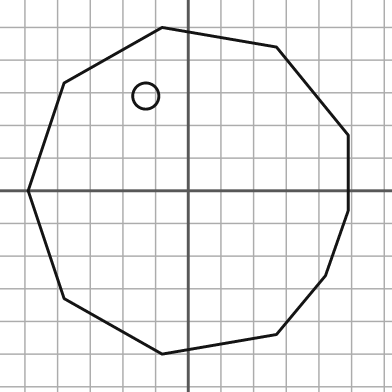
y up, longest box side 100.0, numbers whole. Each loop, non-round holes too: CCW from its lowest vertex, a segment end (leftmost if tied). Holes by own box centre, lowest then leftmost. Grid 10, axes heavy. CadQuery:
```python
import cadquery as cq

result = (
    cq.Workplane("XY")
    .moveTo(-8.0, -50.0)
    .lineTo(27.0, -44.0)
    .lineTo(42.0, -26.0)
    .lineTo(49.0, -6.0)
    .lineTo(49.0, 17.0)
    .lineTo(27.0, 44.0)
    .lineTo(-8.0, 50.0)
    .lineTo(-38.0, 33.0)
    .lineTo(-49.0, 0.0)
    .lineTo(-38.0, -33.0)
    .close()
    .moveTo(-13.0, 29.0)
    .circle(4.0)
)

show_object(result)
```